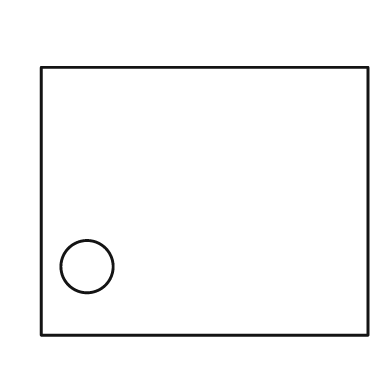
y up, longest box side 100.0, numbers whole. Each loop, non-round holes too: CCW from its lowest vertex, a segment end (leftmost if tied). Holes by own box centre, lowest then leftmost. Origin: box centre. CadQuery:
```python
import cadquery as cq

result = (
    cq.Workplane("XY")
    .moveTo(-50.0, -41.0)
    .lineTo(50.0, -41.0)
    .lineTo(50.0, 41.0)
    .lineTo(-50.0, 41.0)
    .close()
    .moveTo(-36.0, -20.0)
    .circle(8.0)
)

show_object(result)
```